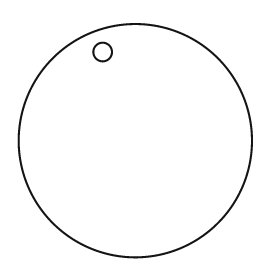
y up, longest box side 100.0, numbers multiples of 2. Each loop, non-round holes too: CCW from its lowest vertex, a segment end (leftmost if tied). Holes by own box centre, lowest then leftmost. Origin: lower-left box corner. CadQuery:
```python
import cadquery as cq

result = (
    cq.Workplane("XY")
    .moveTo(50.0, 50.0)
    .circle(50.0)
    .moveTo(36.0, 88.0)
    .circle(4.0)
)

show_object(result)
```